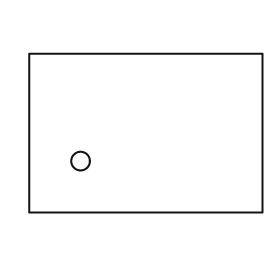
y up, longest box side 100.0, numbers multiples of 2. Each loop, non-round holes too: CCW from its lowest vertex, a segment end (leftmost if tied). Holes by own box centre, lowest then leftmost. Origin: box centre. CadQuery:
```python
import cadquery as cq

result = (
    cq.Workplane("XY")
    .moveTo(-50.0, -34.0)
    .lineTo(50.0, -34.0)
    .lineTo(50.0, 34.0)
    .lineTo(-50.0, 34.0)
    .close()
    .moveTo(-28.0, -12.0)
    .circle(4.0)
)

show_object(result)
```